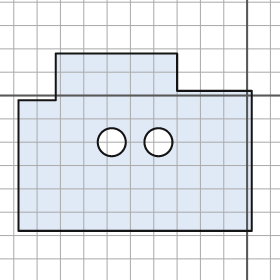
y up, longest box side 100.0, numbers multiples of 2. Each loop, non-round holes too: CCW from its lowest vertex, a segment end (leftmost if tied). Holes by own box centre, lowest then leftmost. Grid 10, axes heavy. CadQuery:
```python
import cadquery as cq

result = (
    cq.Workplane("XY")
    .moveTo(-98.0, -58.0)
    .lineTo(2.0, -58.0)
    .lineTo(2.0, 2.0)
    .lineTo(-30.0, 2.0)
    .lineTo(-30.0, 18.0)
    .lineTo(-82.0, 18.0)
    .lineTo(-82.0, -2.0)
    .lineTo(-98.0, -2.0)
    .close()
    .moveTo(-58.0, -20.0)
    .circle(6.0)
    .moveTo(-38.0, -20.0)
    .circle(6.0)
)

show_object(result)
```